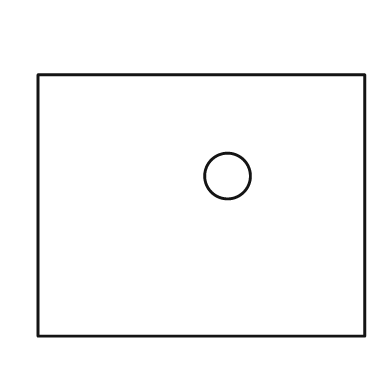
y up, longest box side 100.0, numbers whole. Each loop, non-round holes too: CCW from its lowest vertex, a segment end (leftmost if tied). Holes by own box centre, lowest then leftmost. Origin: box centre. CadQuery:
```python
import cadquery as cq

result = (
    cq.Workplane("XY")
    .moveTo(-50.0, -40.0)
    .lineTo(50.0, -40.0)
    .lineTo(50.0, 40.0)
    .lineTo(-50.0, 40.0)
    .close()
    .moveTo(8.0, 9.0)
    .circle(7.0)
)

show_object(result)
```